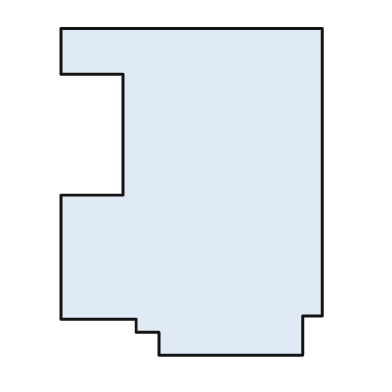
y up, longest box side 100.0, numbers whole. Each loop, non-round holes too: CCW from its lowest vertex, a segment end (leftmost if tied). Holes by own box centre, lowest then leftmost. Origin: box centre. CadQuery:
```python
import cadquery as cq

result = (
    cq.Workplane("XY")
    .moveTo(-10.0, -50.0)
    .lineTo(34.0, -50.0)
    .lineTo(34.0, -38.0)
    .lineTo(40.0, -38.0)
    .lineTo(40.0, 50.0)
    .lineTo(-40.0, 50.0)
    .lineTo(-40.0, 36.0)
    .lineTo(-21.0, 36.0)
    .lineTo(-21.0, -1.0)
    .lineTo(-40.0, -1.0)
    .lineTo(-40.0, -39.0)
    .lineTo(-17.0, -39.0)
    .lineTo(-17.0, -43.0)
    .lineTo(-10.0, -43.0)
    .close()
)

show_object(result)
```